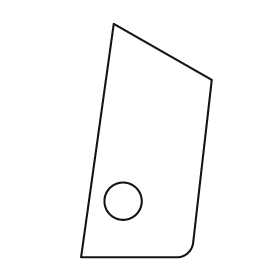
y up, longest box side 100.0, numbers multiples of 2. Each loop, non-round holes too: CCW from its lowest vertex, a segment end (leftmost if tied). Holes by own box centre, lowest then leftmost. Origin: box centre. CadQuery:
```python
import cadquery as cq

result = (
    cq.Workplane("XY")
    .moveTo(-28.0, -50.0)
    .lineTo(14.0, -50.0)
    .threePointArc((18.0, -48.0), (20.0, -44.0))
    .lineTo(28.0, 26.0)
    .lineTo(-14.0, 50.0)
    .close()
    .moveTo(-10.0, -26.0)
    .circle(8.0)
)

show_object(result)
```